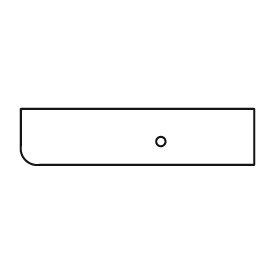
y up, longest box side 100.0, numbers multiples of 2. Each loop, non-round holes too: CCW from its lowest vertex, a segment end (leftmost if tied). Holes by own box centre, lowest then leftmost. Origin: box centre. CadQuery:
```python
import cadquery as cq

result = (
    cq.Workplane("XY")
    .moveTo(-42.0, -12.0)
    .lineTo(50.0, -12.0)
    .lineTo(50.0, 12.0)
    .lineTo(-50.0, 12.0)
    .lineTo(-50.0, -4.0)
    .threePointArc((-48.0, -10.0), (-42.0, -12.0))
    .close()
    .moveTo(10.0, -2.0)
    .circle(2.0)
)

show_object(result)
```